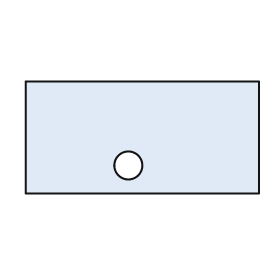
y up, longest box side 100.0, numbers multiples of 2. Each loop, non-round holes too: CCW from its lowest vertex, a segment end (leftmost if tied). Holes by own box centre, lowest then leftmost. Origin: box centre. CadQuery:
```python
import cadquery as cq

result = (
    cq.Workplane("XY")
    .moveTo(-50.0, -24.0)
    .lineTo(50.0, -24.0)
    .lineTo(50.0, 24.0)
    .lineTo(-50.0, 24.0)
    .close()
    .moveTo(-6.0, -12.0)
    .circle(6.0)
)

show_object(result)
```